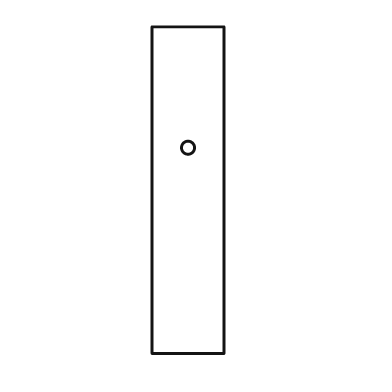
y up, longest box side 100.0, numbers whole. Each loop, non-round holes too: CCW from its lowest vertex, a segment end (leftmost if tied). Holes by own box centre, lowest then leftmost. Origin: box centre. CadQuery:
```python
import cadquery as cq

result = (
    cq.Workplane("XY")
    .moveTo(-11.0, -50.0)
    .lineTo(11.0, -50.0)
    .lineTo(11.0, 50.0)
    .lineTo(-11.0, 50.0)
    .close()
    .moveTo(0.0, 13.0)
    .circle(2.0)
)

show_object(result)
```